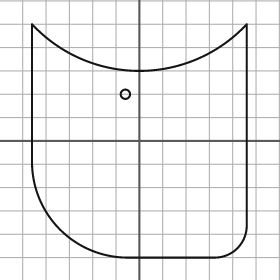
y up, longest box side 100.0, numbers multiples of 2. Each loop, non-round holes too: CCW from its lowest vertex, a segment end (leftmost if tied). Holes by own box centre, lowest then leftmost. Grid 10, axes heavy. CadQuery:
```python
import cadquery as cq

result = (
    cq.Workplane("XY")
    .moveTo(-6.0, -50.0)
    .lineTo(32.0, -50.0)
    .threePointArc((42.0, -46.0), (46.0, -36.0))
    .lineTo(46.0, 50.0)
    .threePointArc((0.0, 30.0), (-46.0, 50.0))
    .lineTo(-46.0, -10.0)
    .threePointArc((-34.0, -38.0), (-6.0, -50.0))
    .close()
    .moveTo(-6.0, 20.0)
    .circle(2.0)
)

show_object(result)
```